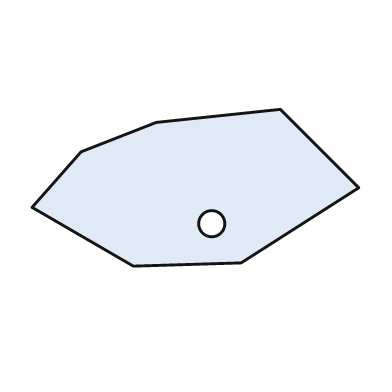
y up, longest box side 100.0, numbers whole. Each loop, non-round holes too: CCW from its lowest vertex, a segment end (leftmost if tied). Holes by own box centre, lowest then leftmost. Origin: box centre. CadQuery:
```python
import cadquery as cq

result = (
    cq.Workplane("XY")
    .moveTo(-19.0, -24.0)
    .lineTo(14.0, -23.0)
    .lineTo(50.0, 0.0)
    .lineTo(26.0, 24.0)
    .lineTo(-12.0, 20.0)
    .lineTo(-35.0, 11.0)
    .lineTo(-50.0, -6.0)
    .close()
    .moveTo(5.0, -11.0)
    .circle(4.0)
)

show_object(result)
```